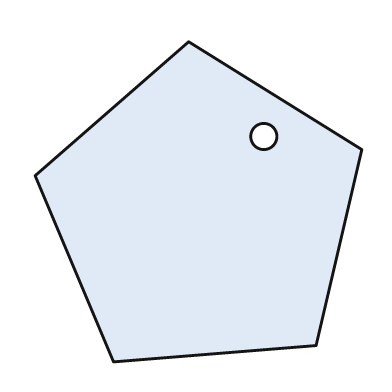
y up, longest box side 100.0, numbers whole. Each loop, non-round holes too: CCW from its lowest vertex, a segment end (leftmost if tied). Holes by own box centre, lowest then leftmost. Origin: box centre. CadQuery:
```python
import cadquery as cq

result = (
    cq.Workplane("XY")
    .moveTo(-26.0, -49.0)
    .lineTo(36.0, -44.0)
    .lineTo(50.0, 16.0)
    .lineTo(-3.0, 49.0)
    .lineTo(-50.0, 8.0)
    .close()
    .moveTo(20.0, 20.0)
    .circle(4.0)
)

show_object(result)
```